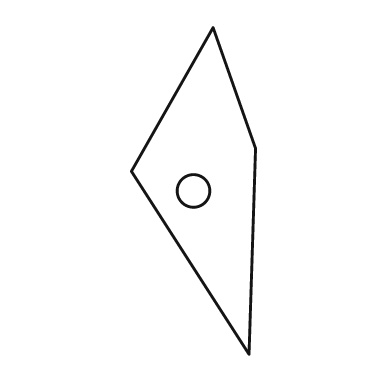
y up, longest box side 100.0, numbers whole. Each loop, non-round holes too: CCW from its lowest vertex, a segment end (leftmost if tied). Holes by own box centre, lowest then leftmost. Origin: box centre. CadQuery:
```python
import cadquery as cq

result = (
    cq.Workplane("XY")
    .moveTo(17.0, -50.0)
    .lineTo(19.0, 13.0)
    .lineTo(6.0, 50.0)
    .lineTo(-19.0, 6.0)
    .close()
    .moveTo(0.0, 0.0)
    .circle(5.0)
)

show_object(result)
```